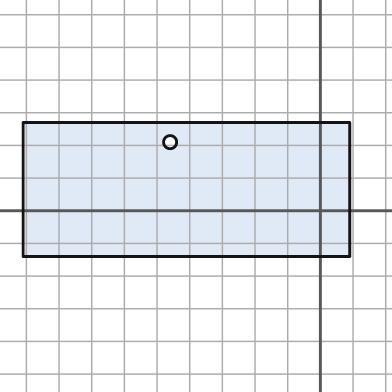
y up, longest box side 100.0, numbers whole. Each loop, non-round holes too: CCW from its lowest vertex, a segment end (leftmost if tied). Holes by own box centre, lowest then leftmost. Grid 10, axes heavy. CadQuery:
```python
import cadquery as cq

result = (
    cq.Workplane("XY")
    .moveTo(-91.0, -14.0)
    .lineTo(9.0, -14.0)
    .lineTo(9.0, 27.0)
    .lineTo(-91.0, 27.0)
    .close()
    .moveTo(-46.0, 21.0)
    .circle(2.0)
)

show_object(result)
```